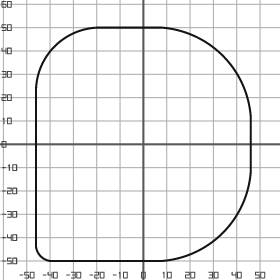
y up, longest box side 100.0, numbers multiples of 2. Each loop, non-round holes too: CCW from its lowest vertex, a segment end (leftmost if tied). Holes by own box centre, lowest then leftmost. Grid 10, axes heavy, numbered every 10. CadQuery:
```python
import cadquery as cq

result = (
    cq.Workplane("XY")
    .moveTo(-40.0, -50.0)
    .lineTo(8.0, -50.0)
    .threePointArc((34.0, -38.0), (46.0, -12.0))
    .lineTo(46.0, 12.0)
    .threePointArc((34.0, 38.0), (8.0, 50.0))
    .lineTo(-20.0, 50.0)
    .threePointArc((-38.0, 42.0), (-46.0, 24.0))
    .lineTo(-46.0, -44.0)
    .threePointArc((-44.0, -48.0), (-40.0, -50.0))
    .close()
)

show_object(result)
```